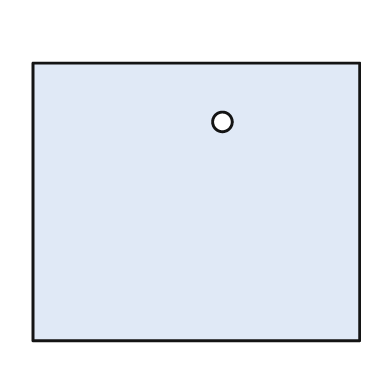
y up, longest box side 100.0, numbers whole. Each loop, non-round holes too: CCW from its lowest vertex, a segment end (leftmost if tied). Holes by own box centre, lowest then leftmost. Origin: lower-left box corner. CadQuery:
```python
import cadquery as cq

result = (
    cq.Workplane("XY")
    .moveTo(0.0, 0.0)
    .lineTo(100.0, 0.0)
    .lineTo(100.0, 85.0)
    .lineTo(0.0, 85.0)
    .close()
    .moveTo(58.0, 67.0)
    .circle(3.0)
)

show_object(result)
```